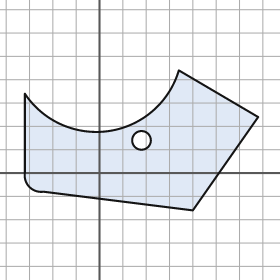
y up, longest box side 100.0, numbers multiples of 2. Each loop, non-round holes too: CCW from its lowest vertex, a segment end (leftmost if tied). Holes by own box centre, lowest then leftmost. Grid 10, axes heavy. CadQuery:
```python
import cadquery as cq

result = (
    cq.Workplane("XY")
    .moveTo(40.0, -16.0)
    .lineTo(68.0, 24.0)
    .lineTo(34.0, 44.0)
    .threePointArc((4.0, 18.0), (-32.0, 34.0))
    .lineTo(-32.0, 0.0)
    .threePointArc((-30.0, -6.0), (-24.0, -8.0))
    .close()
    .moveTo(18.0, 14.0)
    .circle(4.0)
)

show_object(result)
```